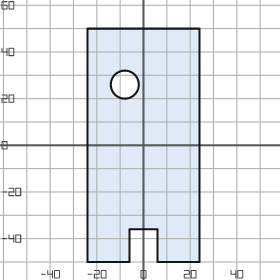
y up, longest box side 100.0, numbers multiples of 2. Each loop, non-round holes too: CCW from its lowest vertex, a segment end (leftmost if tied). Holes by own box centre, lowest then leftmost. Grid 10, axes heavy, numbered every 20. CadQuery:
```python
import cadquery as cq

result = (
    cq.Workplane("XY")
    .moveTo(-24.0, -50.0)
    .lineTo(-6.0, -50.0)
    .lineTo(-6.0, -36.0)
    .lineTo(6.0, -36.0)
    .lineTo(6.0, -50.0)
    .lineTo(24.0, -50.0)
    .lineTo(24.0, 50.0)
    .lineTo(-24.0, 50.0)
    .close()
    .moveTo(-8.0, 26.0)
    .circle(6.0)
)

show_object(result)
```